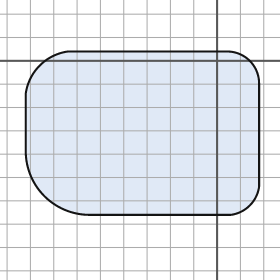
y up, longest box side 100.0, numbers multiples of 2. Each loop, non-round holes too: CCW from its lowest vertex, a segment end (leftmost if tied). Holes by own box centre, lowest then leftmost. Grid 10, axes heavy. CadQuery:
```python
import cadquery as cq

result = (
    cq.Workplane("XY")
    .moveTo(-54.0, -66.0)
    .lineTo(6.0, -66.0)
    .threePointArc((14.0, -62.0), (18.0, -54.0))
    .lineTo(18.0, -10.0)
    .threePointArc((14.0, 0.0), (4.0, 4.0))
    .lineTo(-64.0, 4.0)
    .threePointArc((-76.0, -2.0), (-82.0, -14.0))
    .lineTo(-82.0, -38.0)
    .threePointArc((-74.0, -58.0), (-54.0, -66.0))
    .close()
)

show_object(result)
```